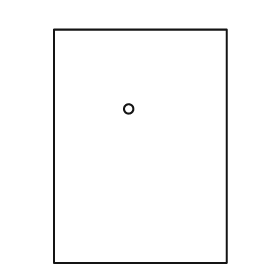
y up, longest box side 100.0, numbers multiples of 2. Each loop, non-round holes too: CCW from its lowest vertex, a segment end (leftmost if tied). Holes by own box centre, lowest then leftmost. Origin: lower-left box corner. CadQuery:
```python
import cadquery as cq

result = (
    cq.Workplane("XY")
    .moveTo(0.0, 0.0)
    .lineTo(74.0, 0.0)
    .lineTo(74.0, 100.0)
    .lineTo(0.0, 100.0)
    .close()
    .moveTo(32.0, 66.0)
    .circle(2.0)
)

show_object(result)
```